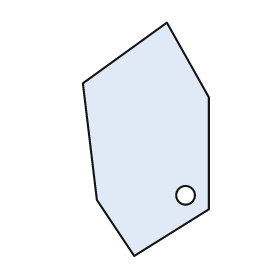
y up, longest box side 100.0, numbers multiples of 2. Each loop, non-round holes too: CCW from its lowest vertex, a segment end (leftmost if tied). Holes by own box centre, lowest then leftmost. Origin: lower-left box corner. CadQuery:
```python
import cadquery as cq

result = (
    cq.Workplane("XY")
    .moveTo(22.0, 0.0)
    .lineTo(54.0, 20.0)
    .lineTo(54.0, 68.0)
    .lineTo(36.0, 100.0)
    .lineTo(0.0, 74.0)
    .lineTo(6.0, 24.0)
    .close()
    .moveTo(44.0, 26.0)
    .circle(4.0)
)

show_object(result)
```